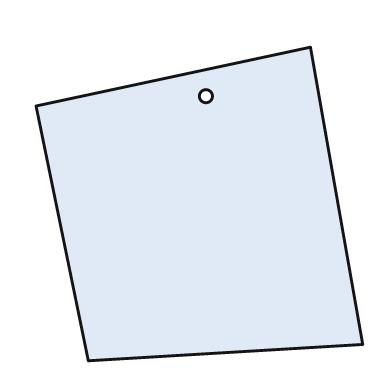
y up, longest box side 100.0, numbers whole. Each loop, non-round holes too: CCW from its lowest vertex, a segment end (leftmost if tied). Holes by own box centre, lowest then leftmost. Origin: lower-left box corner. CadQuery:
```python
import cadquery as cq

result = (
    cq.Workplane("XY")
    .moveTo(16.0, 0.0)
    .lineTo(100.0, 5.0)
    .lineTo(84.0, 96.0)
    .lineTo(0.0, 78.0)
    .close()
    .moveTo(52.0, 81.0)
    .circle(2.0)
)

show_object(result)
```